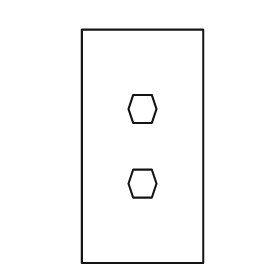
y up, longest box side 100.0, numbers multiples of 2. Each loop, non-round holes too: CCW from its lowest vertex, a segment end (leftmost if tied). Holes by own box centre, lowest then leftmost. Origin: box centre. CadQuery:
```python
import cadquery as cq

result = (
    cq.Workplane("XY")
    .moveTo(-26.0, -50.0)
    .lineTo(26.0, -50.0)
    .lineTo(26.0, 50.0)
    .lineTo(-26.0, 50.0)
    .close()
    .moveTo(-4.0, -22.0)
    .lineTo(4.0, -22.0)
    .lineTo(6.0, -16.0)
    .lineTo(4.0, -10.0)
    .lineTo(-4.0, -10.0)
    .lineTo(-6.0, -16.0)
    .close()
    .moveTo(-4.0, 10.0)
    .lineTo(4.0, 10.0)
    .lineTo(6.0, 16.0)
    .lineTo(4.0, 22.0)
    .lineTo(-4.0, 22.0)
    .lineTo(-6.0, 16.0)
    .close()
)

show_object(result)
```